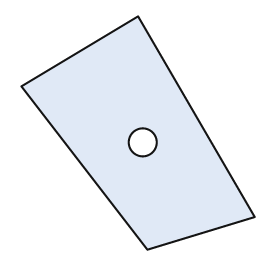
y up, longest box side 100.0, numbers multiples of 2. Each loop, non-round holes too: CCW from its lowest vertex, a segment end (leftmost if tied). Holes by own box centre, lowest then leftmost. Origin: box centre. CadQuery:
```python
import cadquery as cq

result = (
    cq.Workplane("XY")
    .moveTo(4.0, -50.0)
    .lineTo(50.0, -36.0)
    .lineTo(0.0, 50.0)
    .lineTo(-50.0, 20.0)
    .close()
    .moveTo(2.0, -4.0)
    .circle(6.0)
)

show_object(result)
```